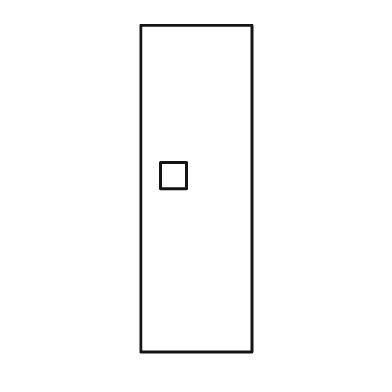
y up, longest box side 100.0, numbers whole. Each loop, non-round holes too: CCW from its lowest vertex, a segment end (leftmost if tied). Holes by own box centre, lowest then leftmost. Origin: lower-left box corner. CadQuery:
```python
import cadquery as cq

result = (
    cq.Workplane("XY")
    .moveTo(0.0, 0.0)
    .lineTo(34.0, 0.0)
    .lineTo(34.0, 100.0)
    .lineTo(0.0, 100.0)
    .close()
    .moveTo(6.0, 50.0)
    .lineTo(14.0, 50.0)
    .lineTo(14.0, 58.0)
    .lineTo(6.0, 58.0)
    .close()
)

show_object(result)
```